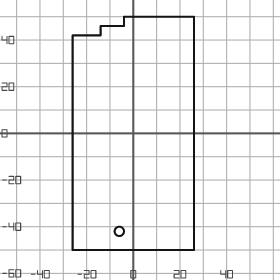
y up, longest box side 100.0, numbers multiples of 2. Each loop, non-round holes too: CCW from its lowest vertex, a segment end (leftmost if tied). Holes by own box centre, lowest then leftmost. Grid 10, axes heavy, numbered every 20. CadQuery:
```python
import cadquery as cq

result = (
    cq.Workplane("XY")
    .moveTo(-26.0, -50.0)
    .lineTo(26.0, -50.0)
    .lineTo(26.0, 50.0)
    .lineTo(-4.0, 50.0)
    .lineTo(-4.0, 46.0)
    .lineTo(-14.0, 46.0)
    .lineTo(-14.0, 42.0)
    .lineTo(-26.0, 42.0)
    .close()
    .moveTo(-6.0, -42.0)
    .circle(2.0)
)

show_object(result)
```